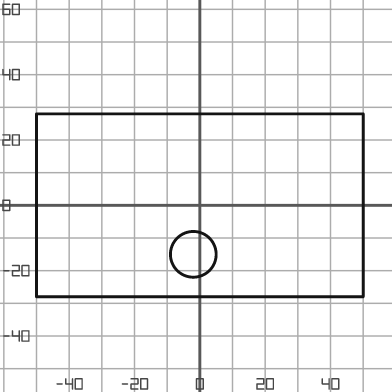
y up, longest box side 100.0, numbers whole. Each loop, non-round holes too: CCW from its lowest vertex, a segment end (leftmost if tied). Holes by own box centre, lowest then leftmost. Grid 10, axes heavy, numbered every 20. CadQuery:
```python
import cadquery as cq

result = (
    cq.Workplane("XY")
    .moveTo(-50.0, -28.0)
    .lineTo(50.0, -28.0)
    .lineTo(50.0, 28.0)
    .lineTo(-50.0, 28.0)
    .close()
    .moveTo(-2.0, -15.0)
    .circle(7.0)
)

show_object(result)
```